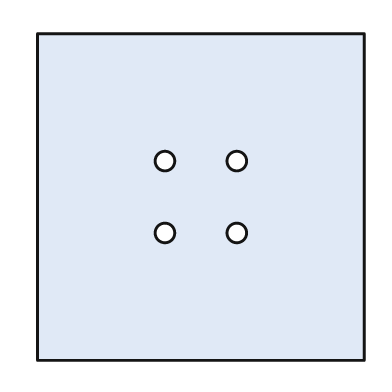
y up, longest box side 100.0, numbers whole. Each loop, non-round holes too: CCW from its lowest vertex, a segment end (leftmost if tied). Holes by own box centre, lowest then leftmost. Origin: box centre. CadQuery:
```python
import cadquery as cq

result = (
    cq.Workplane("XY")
    .moveTo(-50.0, -50.0)
    .lineTo(50.0, -50.0)
    .lineTo(50.0, 50.0)
    .lineTo(-50.0, 50.0)
    .close()
    .moveTo(-11.0, -11.0)
    .circle(3.0)
    .moveTo(11.0, -11.0)
    .circle(3.0)
    .moveTo(-11.0, 11.0)
    .circle(3.0)
    .moveTo(11.0, 11.0)
    .circle(3.0)
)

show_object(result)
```